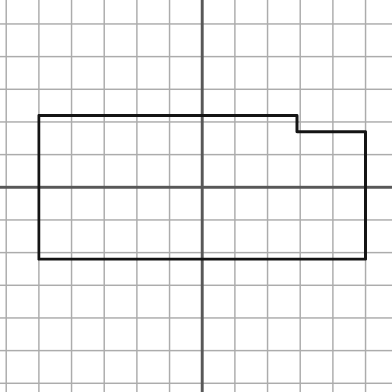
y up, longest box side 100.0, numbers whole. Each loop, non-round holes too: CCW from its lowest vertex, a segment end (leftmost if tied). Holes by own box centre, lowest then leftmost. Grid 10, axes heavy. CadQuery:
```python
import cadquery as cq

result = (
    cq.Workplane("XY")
    .moveTo(-50.0, -22.0)
    .lineTo(50.0, -22.0)
    .lineTo(50.0, 17.0)
    .lineTo(29.0, 17.0)
    .lineTo(29.0, 22.0)
    .lineTo(-50.0, 22.0)
    .close()
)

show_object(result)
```